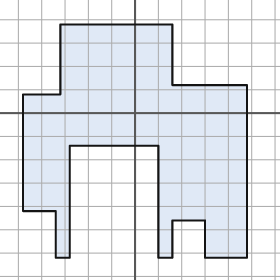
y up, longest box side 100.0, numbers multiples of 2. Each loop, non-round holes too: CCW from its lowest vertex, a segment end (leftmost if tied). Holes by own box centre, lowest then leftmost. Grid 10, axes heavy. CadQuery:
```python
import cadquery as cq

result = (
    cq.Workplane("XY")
    .moveTo(-34.0, -62.0)
    .lineTo(-28.0, -62.0)
    .lineTo(-28.0, -14.0)
    .lineTo(10.0, -14.0)
    .lineTo(10.0, -62.0)
    .lineTo(16.0, -62.0)
    .lineTo(16.0, -46.0)
    .lineTo(30.0, -46.0)
    .lineTo(30.0, -62.0)
    .lineTo(48.0, -62.0)
    .lineTo(48.0, 12.0)
    .lineTo(16.0, 12.0)
    .lineTo(16.0, 38.0)
    .lineTo(-32.0, 38.0)
    .lineTo(-32.0, 8.0)
    .lineTo(-48.0, 8.0)
    .lineTo(-48.0, -42.0)
    .lineTo(-34.0, -42.0)
    .close()
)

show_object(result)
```